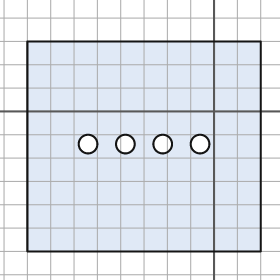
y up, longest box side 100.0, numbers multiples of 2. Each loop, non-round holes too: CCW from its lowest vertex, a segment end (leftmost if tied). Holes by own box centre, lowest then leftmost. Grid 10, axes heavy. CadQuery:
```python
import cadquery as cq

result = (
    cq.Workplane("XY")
    .moveTo(-80.0, -60.0)
    .lineTo(20.0, -60.0)
    .lineTo(20.0, 30.0)
    .lineTo(-80.0, 30.0)
    .close()
    .moveTo(-54.0, -14.0)
    .circle(4.0)
    .moveTo(-38.0, -14.0)
    .circle(4.0)
    .moveTo(-22.0, -14.0)
    .circle(4.0)
    .moveTo(-6.0, -14.0)
    .circle(4.0)
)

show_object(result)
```